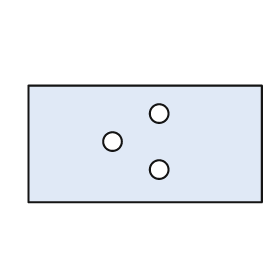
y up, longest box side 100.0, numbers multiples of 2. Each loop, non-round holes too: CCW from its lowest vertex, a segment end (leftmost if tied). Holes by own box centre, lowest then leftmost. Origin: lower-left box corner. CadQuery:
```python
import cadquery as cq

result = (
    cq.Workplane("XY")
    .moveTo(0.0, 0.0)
    .lineTo(100.0, 0.0)
    .lineTo(100.0, 50.0)
    .lineTo(0.0, 50.0)
    .close()
    .moveTo(56.0, 14.0)
    .circle(4.0)
    .moveTo(36.0, 26.0)
    .circle(4.0)
    .moveTo(56.0, 38.0)
    .circle(4.0)
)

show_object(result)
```